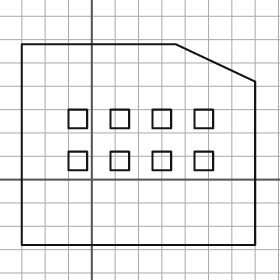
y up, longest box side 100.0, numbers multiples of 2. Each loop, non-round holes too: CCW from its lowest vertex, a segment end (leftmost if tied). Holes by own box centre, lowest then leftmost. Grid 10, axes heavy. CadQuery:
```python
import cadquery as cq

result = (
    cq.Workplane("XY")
    .moveTo(-30.0, -28.0)
    .lineTo(70.0, -28.0)
    .lineTo(70.0, 42.0)
    .lineTo(36.0, 58.0)
    .lineTo(-30.0, 58.0)
    .close()
    .moveTo(-10.0, 4.0)
    .lineTo(-2.0, 4.0)
    .lineTo(-2.0, 12.0)
    .lineTo(-10.0, 12.0)
    .close()
    .moveTo(8.0, 4.0)
    .lineTo(16.0, 4.0)
    .lineTo(16.0, 12.0)
    .lineTo(8.0, 12.0)
    .close()
    .moveTo(26.0, 4.0)
    .lineTo(34.0, 4.0)
    .lineTo(34.0, 12.0)
    .lineTo(26.0, 12.0)
    .close()
    .moveTo(44.0, 4.0)
    .lineTo(52.0, 4.0)
    .lineTo(52.0, 12.0)
    .lineTo(44.0, 12.0)
    .close()
    .moveTo(-10.0, 22.0)
    .lineTo(-2.0, 22.0)
    .lineTo(-2.0, 30.0)
    .lineTo(-10.0, 30.0)
    .close()
    .moveTo(8.0, 22.0)
    .lineTo(16.0, 22.0)
    .lineTo(16.0, 30.0)
    .lineTo(8.0, 30.0)
    .close()
    .moveTo(26.0, 22.0)
    .lineTo(34.0, 22.0)
    .lineTo(34.0, 30.0)
    .lineTo(26.0, 30.0)
    .close()
    .moveTo(44.0, 22.0)
    .lineTo(52.0, 22.0)
    .lineTo(52.0, 30.0)
    .lineTo(44.0, 30.0)
    .close()
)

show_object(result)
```